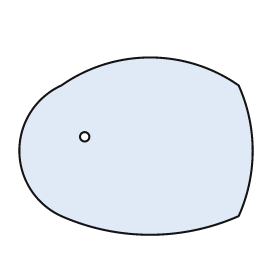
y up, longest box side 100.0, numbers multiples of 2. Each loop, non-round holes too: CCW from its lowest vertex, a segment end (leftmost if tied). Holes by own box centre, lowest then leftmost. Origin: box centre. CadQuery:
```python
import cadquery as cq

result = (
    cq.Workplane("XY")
    .moveTo(-32.0, -30.0)
    .threePointArc((6.0, -38.0), (44.0, -30.0))
    .threePointArc((50.0, -2.0), (44.0, 26.0))
    .threePointArc((6.0, 38.0), (-32.0, 26.0))
    .threePointArc((-50.0, -2.0), (-32.0, -30.0))
    .close()
    .moveTo(-22.0, 4.0)
    .circle(2.0)
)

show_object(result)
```